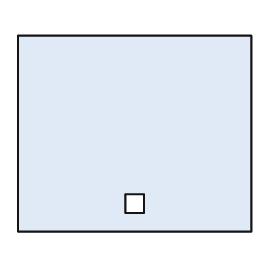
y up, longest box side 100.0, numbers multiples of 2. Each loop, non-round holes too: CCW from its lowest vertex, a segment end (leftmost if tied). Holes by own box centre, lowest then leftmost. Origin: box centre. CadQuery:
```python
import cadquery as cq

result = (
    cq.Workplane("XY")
    .moveTo(-50.0, -42.0)
    .lineTo(50.0, -42.0)
    .lineTo(50.0, 42.0)
    .lineTo(-50.0, 42.0)
    .close()
    .moveTo(-4.0, -34.0)
    .lineTo(4.0, -34.0)
    .lineTo(4.0, -26.0)
    .lineTo(-4.0, -26.0)
    .close()
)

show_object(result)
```